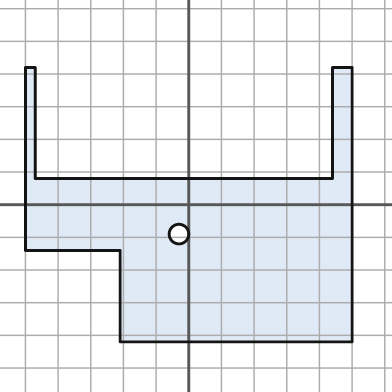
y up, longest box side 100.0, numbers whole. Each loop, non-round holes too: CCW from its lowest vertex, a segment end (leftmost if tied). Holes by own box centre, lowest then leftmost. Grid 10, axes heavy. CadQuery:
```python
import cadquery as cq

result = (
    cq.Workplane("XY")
    .moveTo(-21.0, -42.0)
    .lineTo(50.0, -42.0)
    .lineTo(50.0, 42.0)
    .lineTo(44.0, 42.0)
    .lineTo(44.0, 8.0)
    .lineTo(-47.0, 8.0)
    .lineTo(-47.0, 42.0)
    .lineTo(-50.0, 42.0)
    .lineTo(-50.0, -14.0)
    .lineTo(-21.0, -14.0)
    .close()
    .moveTo(-3.0, -9.0)
    .circle(3.0)
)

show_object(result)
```